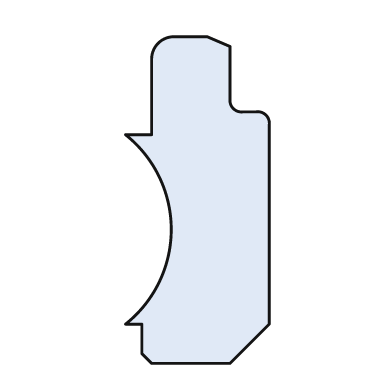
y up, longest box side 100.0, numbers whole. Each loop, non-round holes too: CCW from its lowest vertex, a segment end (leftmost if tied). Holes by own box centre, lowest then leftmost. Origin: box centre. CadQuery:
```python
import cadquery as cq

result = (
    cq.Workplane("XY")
    .moveTo(-14.0, -50.0)
    .lineTo(10.0, -50.0)
    .lineTo(22.0, -38.0)
    .lineTo(22.0, 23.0)
    .threePointArc((21.0, 26.0), (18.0, 27.0))
    .lineTo(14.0, 27.0)
    .threePointArc((11.0, 28.0), (10.0, 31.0))
    .lineTo(10.0, 47.0)
    .lineTo(3.0, 50.0)
    .lineTo(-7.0, 50.0)
    .threePointArc((-12.0, 48.0), (-14.0, 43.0))
    .lineTo(-14.0, 20.0)
    .lineTo(-22.0, 20.0)
    .threePointArc((-8.0, -9.0), (-22.0, -38.0))
    .lineTo(-17.0, -38.0)
    .lineTo(-17.0, -47.0)
    .close()
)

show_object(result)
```